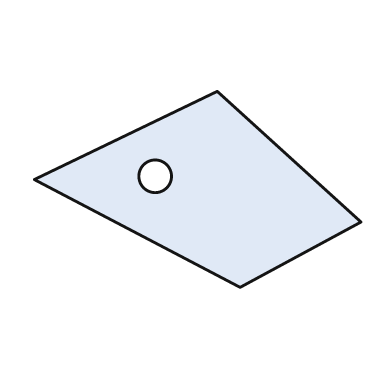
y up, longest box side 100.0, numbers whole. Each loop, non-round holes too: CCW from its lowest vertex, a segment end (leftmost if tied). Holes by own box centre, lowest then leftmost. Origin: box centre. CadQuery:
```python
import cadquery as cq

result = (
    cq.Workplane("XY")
    .moveTo(13.0, -30.0)
    .lineTo(50.0, -10.0)
    .lineTo(6.0, 30.0)
    .lineTo(-50.0, 3.0)
    .close()
    .moveTo(-13.0, 4.0)
    .circle(5.0)
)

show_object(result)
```